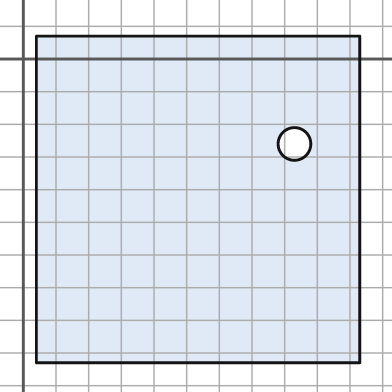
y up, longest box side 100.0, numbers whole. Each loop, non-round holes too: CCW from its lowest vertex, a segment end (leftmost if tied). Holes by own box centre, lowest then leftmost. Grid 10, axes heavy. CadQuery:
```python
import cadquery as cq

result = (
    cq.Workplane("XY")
    .moveTo(4.0, -93.0)
    .lineTo(103.0, -93.0)
    .lineTo(103.0, 7.0)
    .lineTo(4.0, 7.0)
    .close()
    .moveTo(83.0, -26.0)
    .circle(5.0)
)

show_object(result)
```